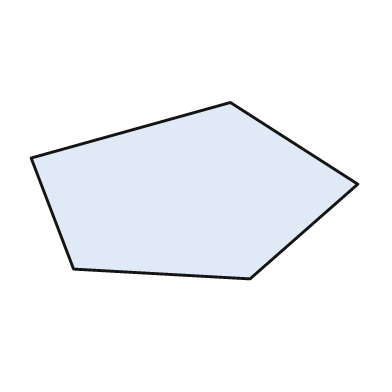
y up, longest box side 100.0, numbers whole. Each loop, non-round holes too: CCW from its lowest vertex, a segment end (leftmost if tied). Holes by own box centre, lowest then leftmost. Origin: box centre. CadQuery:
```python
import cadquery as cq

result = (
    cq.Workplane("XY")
    .moveTo(17.0, -27.0)
    .lineTo(50.0, 2.0)
    .lineTo(11.0, 27.0)
    .lineTo(-50.0, 10.0)
    .lineTo(-37.0, -24.0)
    .close()
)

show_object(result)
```